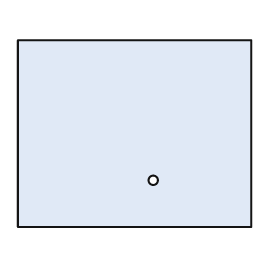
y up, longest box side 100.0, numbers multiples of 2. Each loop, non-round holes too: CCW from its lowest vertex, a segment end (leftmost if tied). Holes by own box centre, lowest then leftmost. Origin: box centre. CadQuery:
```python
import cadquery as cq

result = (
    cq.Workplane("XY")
    .moveTo(-50.0, -40.0)
    .lineTo(50.0, -40.0)
    .lineTo(50.0, 40.0)
    .lineTo(-50.0, 40.0)
    .close()
    .moveTo(8.0, -20.0)
    .circle(2.0)
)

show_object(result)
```